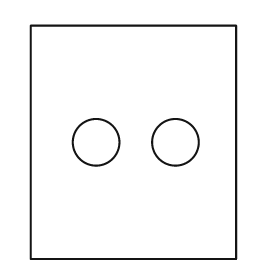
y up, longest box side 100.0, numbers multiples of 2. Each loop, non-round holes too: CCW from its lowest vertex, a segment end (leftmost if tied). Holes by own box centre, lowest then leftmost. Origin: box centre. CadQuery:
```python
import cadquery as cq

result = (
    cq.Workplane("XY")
    .moveTo(-44.0, -50.0)
    .lineTo(44.0, -50.0)
    .lineTo(44.0, 50.0)
    .lineTo(-44.0, 50.0)
    .close()
    .moveTo(-16.0, 0.0)
    .circle(10.0)
    .moveTo(18.0, 0.0)
    .circle(10.0)
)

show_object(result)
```